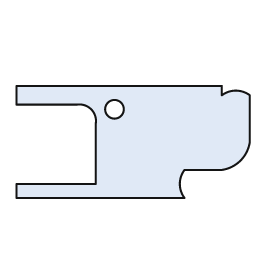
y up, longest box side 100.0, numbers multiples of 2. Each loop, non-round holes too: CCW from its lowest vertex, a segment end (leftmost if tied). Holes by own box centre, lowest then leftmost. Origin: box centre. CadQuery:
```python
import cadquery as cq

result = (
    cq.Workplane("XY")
    .moveTo(-50.0, -24.0)
    .lineTo(22.0, -24.0)
    .threePointArc((20.0, -18.0), (22.0, -12.0))
    .lineTo(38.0, -12.0)
    .threePointArc((46.0, -8.0), (50.0, 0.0))
    .lineTo(50.0, 20.0)
    .threePointArc((44.0, 22.0), (38.0, 20.0))
    .lineTo(38.0, 24.0)
    .lineTo(-50.0, 24.0)
    .lineTo(-50.0, 16.0)
    .lineTo(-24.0, 16.0)
    .threePointArc((-18.0, 14.0), (-16.0, 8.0))
    .lineTo(-16.0, -18.0)
    .lineTo(-50.0, -18.0)
    .close()
    .moveTo(-8.0, 14.0)
    .circle(4.0)
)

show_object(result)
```